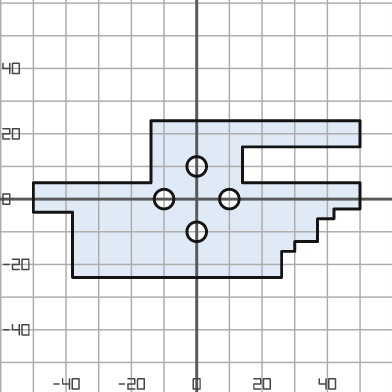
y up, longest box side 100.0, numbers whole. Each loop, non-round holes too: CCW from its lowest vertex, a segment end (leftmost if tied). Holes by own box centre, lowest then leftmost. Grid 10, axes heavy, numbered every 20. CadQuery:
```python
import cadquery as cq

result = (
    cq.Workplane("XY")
    .moveTo(-38.0, -24.0)
    .lineTo(26.0, -24.0)
    .lineTo(26.0, -16.0)
    .lineTo(30.0, -16.0)
    .lineTo(30.0, -13.0)
    .lineTo(37.0, -13.0)
    .lineTo(37.0, -6.0)
    .lineTo(42.0, -6.0)
    .lineTo(42.0, -3.0)
    .lineTo(50.0, -3.0)
    .lineTo(50.0, 5.0)
    .lineTo(14.0, 5.0)
    .lineTo(14.0, 16.0)
    .lineTo(50.0, 16.0)
    .lineTo(50.0, 24.0)
    .lineTo(-14.0, 24.0)
    .lineTo(-14.0, 5.0)
    .lineTo(-50.0, 5.0)
    .lineTo(-50.0, -4.0)
    .lineTo(-38.0, -4.0)
    .close()
    .moveTo(0.0, -10.0)
    .circle(3.0)
    .moveTo(-10.0, 0.0)
    .circle(3.0)
    .moveTo(10.0, 0.0)
    .circle(3.0)
    .moveTo(0.0, 10.0)
    .circle(3.0)
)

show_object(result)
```